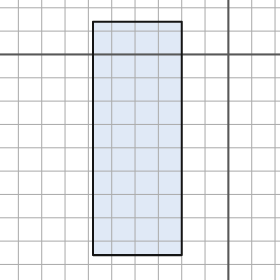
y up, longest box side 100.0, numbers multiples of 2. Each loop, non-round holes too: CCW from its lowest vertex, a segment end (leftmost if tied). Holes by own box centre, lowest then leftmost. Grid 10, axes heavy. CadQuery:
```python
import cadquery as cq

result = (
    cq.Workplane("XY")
    .moveTo(-58.0, -86.0)
    .lineTo(-20.0, -86.0)
    .lineTo(-20.0, 14.0)
    .lineTo(-58.0, 14.0)
    .close()
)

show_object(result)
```